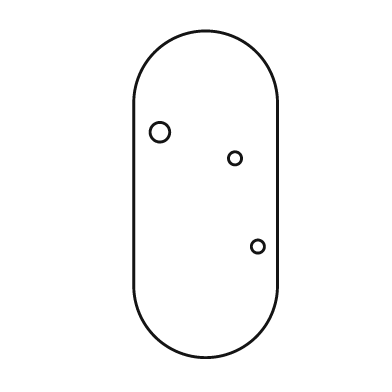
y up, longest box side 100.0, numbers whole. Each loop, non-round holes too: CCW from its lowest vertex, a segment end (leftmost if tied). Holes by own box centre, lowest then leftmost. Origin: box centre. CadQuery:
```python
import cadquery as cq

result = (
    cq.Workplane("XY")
    .moveTo(-22.0, -28.0)
    .threePointArc((0.0, -50.0), (22.0, -28.0))
    .lineTo(22.0, 28.0)
    .threePointArc((0.0, 50.0), (-22.0, 28.0))
    .close()
    .moveTo(16.0, -16.0)
    .circle(2.0)
    .moveTo(9.0, 11.0)
    .circle(2.0)
    .moveTo(-14.0, 19.0)
    .circle(3.0)
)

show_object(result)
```